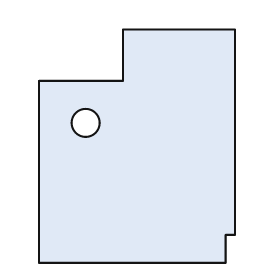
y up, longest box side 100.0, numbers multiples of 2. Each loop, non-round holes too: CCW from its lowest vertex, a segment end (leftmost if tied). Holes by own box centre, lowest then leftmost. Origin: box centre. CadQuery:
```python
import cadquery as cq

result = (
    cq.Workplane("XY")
    .moveTo(-42.0, -50.0)
    .lineTo(38.0, -50.0)
    .lineTo(38.0, -38.0)
    .lineTo(42.0, -38.0)
    .lineTo(42.0, 50.0)
    .lineTo(-6.0, 50.0)
    .lineTo(-6.0, 28.0)
    .lineTo(-42.0, 28.0)
    .close()
    .moveTo(-22.0, 10.0)
    .circle(6.0)
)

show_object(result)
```